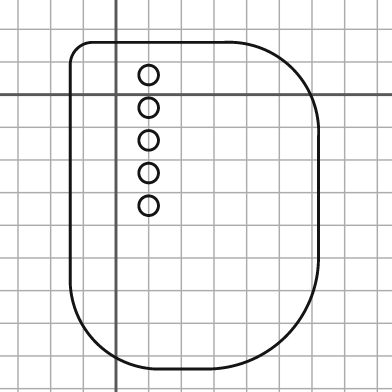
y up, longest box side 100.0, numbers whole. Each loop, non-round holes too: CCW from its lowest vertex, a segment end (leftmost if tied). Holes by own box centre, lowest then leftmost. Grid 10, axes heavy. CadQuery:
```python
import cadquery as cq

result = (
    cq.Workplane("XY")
    .moveTo(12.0, -84.0)
    .lineTo(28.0, -84.0)
    .threePointArc((52.0, -74.0), (62.0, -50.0))
    .lineTo(62.0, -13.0)
    .threePointArc((54.0, 8.0), (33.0, 16.0))
    .lineTo(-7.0, 16.0)
    .threePointArc((-12.0, 14.0), (-14.0, 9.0))
    .lineTo(-14.0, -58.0)
    .threePointArc((-6.0, -76.0), (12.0, -84.0))
    .close()
    .moveTo(10.0, -34.0)
    .circle(3.0)
    .moveTo(10.0, -24.0)
    .circle(3.0)
    .moveTo(10.0, -14.0)
    .circle(3.0)
    .moveTo(10.0, -4.0)
    .circle(3.0)
    .moveTo(10.0, 6.0)
    .circle(3.0)
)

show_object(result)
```